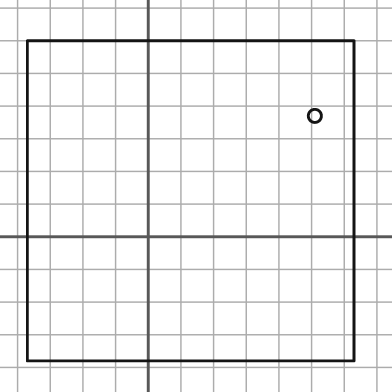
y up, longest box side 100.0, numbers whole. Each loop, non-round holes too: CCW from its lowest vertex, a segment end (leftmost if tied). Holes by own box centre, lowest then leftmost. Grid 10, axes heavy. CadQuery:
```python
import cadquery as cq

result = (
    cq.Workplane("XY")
    .moveTo(-37.0, -38.0)
    .lineTo(63.0, -38.0)
    .lineTo(63.0, 60.0)
    .lineTo(-37.0, 60.0)
    .close()
    .moveTo(51.0, 37.0)
    .circle(2.0)
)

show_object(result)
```